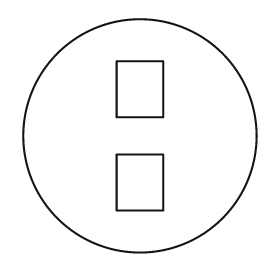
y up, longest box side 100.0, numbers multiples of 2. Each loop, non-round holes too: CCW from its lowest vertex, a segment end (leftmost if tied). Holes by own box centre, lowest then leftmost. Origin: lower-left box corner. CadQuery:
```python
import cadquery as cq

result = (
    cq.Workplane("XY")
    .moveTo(50.0, 50.0)
    .circle(50.0)
    .moveTo(40.0, 18.0)
    .lineTo(60.0, 18.0)
    .lineTo(60.0, 42.0)
    .lineTo(40.0, 42.0)
    .close()
    .moveTo(40.0, 58.0)
    .lineTo(60.0, 58.0)
    .lineTo(60.0, 82.0)
    .lineTo(40.0, 82.0)
    .close()
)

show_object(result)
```